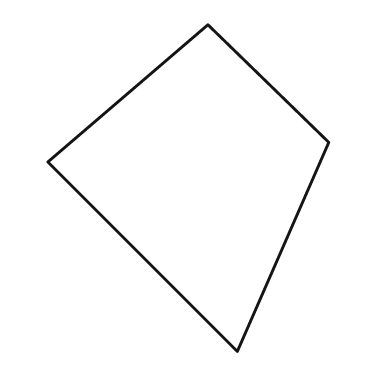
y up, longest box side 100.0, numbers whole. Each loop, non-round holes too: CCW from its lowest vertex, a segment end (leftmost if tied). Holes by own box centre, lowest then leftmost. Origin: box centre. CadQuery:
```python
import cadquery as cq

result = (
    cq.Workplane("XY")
    .moveTo(15.0, -50.0)
    .lineTo(43.0, 14.0)
    .lineTo(6.0, 50.0)
    .lineTo(-43.0, 8.0)
    .close()
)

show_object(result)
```